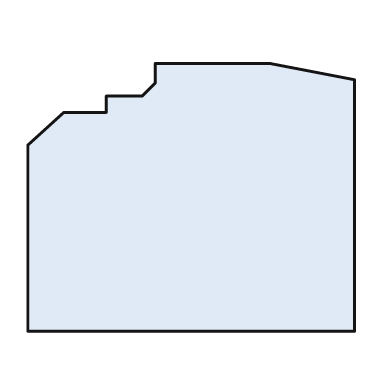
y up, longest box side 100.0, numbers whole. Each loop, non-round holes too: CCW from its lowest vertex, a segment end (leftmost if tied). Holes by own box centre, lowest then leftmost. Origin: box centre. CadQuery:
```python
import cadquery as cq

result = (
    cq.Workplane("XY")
    .moveTo(-50.0, -41.0)
    .lineTo(50.0, -41.0)
    .lineTo(50.0, 36.0)
    .lineTo(24.0, 41.0)
    .lineTo(-11.0, 41.0)
    .lineTo(-11.0, 35.0)
    .lineTo(-15.0, 31.0)
    .lineTo(-26.0, 31.0)
    .lineTo(-26.0, 26.0)
    .lineTo(-39.0, 26.0)
    .lineTo(-50.0, 16.0)
    .close()
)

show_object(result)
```